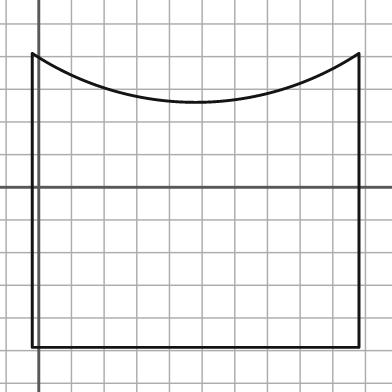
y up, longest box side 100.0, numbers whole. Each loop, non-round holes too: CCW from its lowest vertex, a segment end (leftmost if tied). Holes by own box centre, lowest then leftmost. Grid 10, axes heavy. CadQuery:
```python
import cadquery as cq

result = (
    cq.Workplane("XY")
    .moveTo(-2.0, -49.0)
    .lineTo(98.0, -49.0)
    .lineTo(98.0, 41.0)
    .threePointArc((48.0, 26.0), (-2.0, 41.0))
    .close()
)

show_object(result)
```